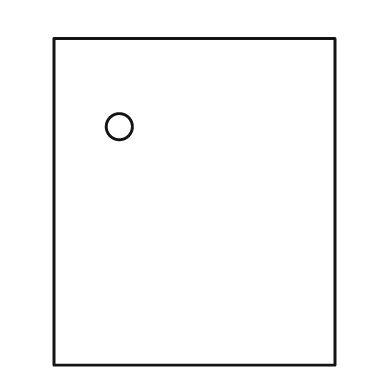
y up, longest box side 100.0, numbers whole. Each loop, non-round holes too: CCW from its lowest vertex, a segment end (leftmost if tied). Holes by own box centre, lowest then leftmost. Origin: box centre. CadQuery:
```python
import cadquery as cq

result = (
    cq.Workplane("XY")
    .moveTo(-43.0, -50.0)
    .lineTo(43.0, -50.0)
    .lineTo(43.0, 50.0)
    .lineTo(-43.0, 50.0)
    .close()
    .moveTo(-23.0, 23.0)
    .circle(4.0)
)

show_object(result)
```